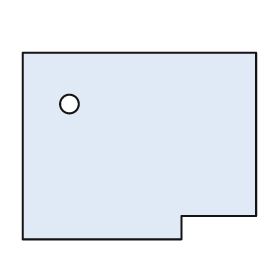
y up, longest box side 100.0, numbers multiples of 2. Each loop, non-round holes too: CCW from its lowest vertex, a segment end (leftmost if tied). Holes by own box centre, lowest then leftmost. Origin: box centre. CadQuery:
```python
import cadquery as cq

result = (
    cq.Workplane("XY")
    .moveTo(-50.0, -40.0)
    .lineTo(18.0, -40.0)
    .lineTo(18.0, -30.0)
    .lineTo(50.0, -30.0)
    .lineTo(50.0, 40.0)
    .lineTo(-50.0, 40.0)
    .close()
    .moveTo(-30.0, 18.0)
    .circle(4.0)
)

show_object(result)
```